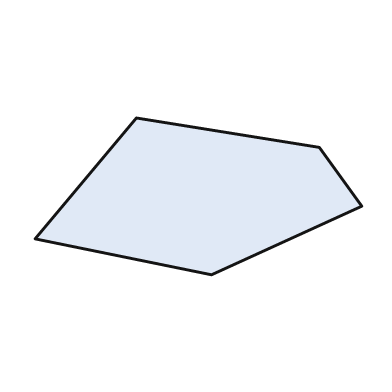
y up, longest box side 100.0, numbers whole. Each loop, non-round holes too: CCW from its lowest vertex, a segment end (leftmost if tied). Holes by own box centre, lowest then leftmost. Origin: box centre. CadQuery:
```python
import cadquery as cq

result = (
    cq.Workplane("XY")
    .moveTo(4.0, -24.0)
    .lineTo(50.0, -3.0)
    .lineTo(37.0, 15.0)
    .lineTo(-19.0, 24.0)
    .lineTo(-50.0, -13.0)
    .close()
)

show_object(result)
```